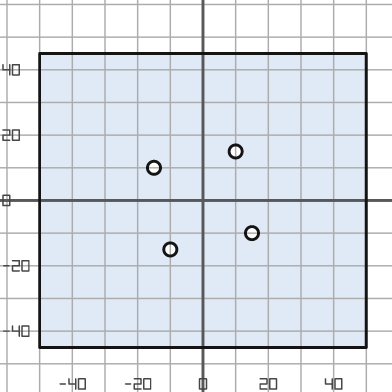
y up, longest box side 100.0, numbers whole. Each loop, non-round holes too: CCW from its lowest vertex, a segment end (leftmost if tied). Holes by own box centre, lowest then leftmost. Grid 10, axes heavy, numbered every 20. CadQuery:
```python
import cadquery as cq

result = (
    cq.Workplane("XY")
    .moveTo(-50.0, -45.0)
    .lineTo(50.0, -45.0)
    .lineTo(50.0, 45.0)
    .lineTo(-50.0, 45.0)
    .close()
    .moveTo(-10.0, -15.0)
    .circle(2.0)
    .moveTo(15.0, -10.0)
    .circle(2.0)
    .moveTo(-15.0, 10.0)
    .circle(2.0)
    .moveTo(10.0, 15.0)
    .circle(2.0)
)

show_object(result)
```